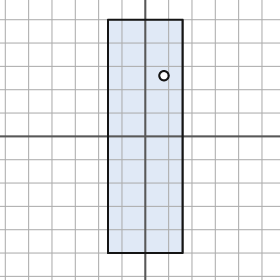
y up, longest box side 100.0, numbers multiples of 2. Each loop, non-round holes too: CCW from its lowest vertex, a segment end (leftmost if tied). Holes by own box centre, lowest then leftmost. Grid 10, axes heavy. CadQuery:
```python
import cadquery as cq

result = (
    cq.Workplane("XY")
    .moveTo(-16.0, -50.0)
    .lineTo(16.0, -50.0)
    .lineTo(16.0, 50.0)
    .lineTo(-16.0, 50.0)
    .close()
    .moveTo(8.0, 26.0)
    .circle(2.0)
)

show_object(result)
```